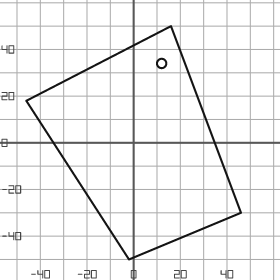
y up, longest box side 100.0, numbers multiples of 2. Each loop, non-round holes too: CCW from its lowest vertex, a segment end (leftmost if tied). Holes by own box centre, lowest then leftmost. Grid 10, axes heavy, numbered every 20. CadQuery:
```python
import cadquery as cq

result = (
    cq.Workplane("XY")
    .moveTo(-2.0, -50.0)
    .lineTo(46.0, -30.0)
    .lineTo(16.0, 50.0)
    .lineTo(-46.0, 18.0)
    .close()
    .moveTo(12.0, 34.0)
    .circle(2.0)
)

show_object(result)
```